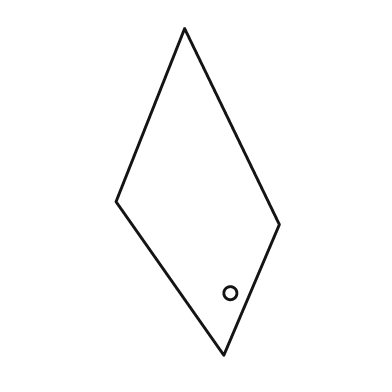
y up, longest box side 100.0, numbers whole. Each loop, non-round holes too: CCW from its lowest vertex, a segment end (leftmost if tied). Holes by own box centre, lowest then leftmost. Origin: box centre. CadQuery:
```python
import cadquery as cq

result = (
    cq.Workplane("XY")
    .moveTo(8.0, -50.0)
    .lineTo(25.0, -10.0)
    .lineTo(-4.0, 50.0)
    .lineTo(-25.0, -3.0)
    .close()
    .moveTo(10.0, -31.0)
    .circle(2.0)
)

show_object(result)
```